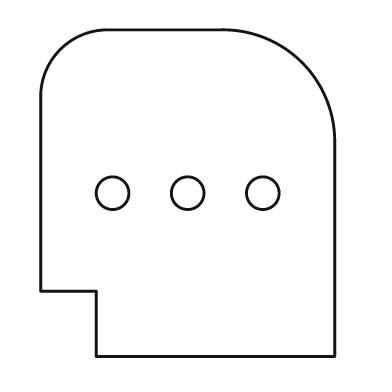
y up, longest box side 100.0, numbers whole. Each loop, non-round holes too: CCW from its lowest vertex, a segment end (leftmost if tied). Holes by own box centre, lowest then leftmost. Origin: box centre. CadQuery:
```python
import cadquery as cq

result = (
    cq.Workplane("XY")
    .moveTo(-28.0, -50.0)
    .lineTo(45.0, -50.0)
    .lineTo(45.0, 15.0)
    .threePointArc((35.0, 40.0), (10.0, 50.0))
    .lineTo(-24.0, 50.0)
    .threePointArc((-39.0, 44.0), (-45.0, 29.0))
    .lineTo(-45.0, -30.0)
    .lineTo(-28.0, -30.0)
    .close()
    .moveTo(-23.0, 0.0)
    .circle(5.0)
    .moveTo(0.0, 0.0)
    .circle(5.0)
    .moveTo(23.0, 0.0)
    .circle(5.0)
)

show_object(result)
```